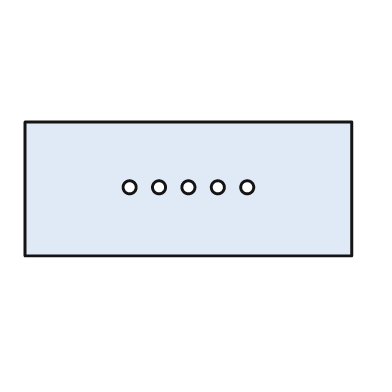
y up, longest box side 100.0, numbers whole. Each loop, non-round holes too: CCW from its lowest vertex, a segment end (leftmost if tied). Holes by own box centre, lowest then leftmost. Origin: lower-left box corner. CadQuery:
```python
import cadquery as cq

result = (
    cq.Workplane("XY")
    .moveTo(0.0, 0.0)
    .lineTo(100.0, 0.0)
    .lineTo(100.0, 41.0)
    .lineTo(0.0, 41.0)
    .close()
    .moveTo(32.0, 21.0)
    .circle(2.0)
    .moveTo(41.0, 21.0)
    .circle(2.0)
    .moveTo(50.0, 21.0)
    .circle(2.0)
    .moveTo(59.0, 21.0)
    .circle(2.0)
    .moveTo(68.0, 21.0)
    .circle(2.0)
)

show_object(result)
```